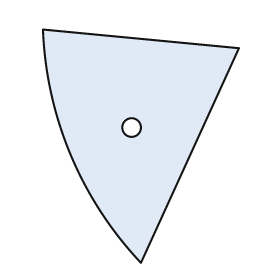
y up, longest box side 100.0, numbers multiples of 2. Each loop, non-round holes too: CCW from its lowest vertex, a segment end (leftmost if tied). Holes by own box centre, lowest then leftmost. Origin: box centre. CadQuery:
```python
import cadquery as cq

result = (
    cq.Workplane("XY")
    .moveTo(0.0, -50.0)
    .lineTo(42.0, 42.0)
    .lineTo(-42.0, 50.0)
    .threePointArc((-30.0, -4.0), (0.0, -50.0))
    .close()
    .moveTo(-4.0, 8.0)
    .circle(4.0)
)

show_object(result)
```